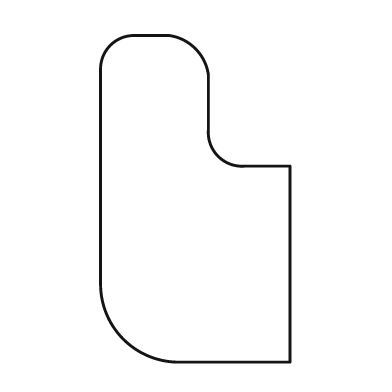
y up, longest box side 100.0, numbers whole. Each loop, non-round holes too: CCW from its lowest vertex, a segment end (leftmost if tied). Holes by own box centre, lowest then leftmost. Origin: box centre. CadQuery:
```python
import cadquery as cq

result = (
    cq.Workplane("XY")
    .moveTo(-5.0, -50.0)
    .lineTo(29.0, -50.0)
    .lineTo(29.0, 10.0)
    .lineTo(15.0, 10.0)
    .threePointArc((7.0, 13.0), (4.0, 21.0))
    .lineTo(4.0, 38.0)
    .threePointArc((0.0, 46.0), (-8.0, 50.0))
    .lineTo(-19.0, 50.0)
    .threePointArc((-26.0, 47.0), (-29.0, 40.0))
    .lineTo(-29.0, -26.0)
    .threePointArc((-22.0, -43.0), (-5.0, -50.0))
    .close()
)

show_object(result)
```